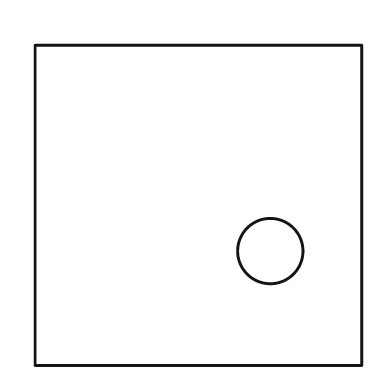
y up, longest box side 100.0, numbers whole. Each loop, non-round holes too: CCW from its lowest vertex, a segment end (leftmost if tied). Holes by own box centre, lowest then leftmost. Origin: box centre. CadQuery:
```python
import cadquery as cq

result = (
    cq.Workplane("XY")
    .moveTo(-50.0, -49.0)
    .lineTo(50.0, -49.0)
    .lineTo(50.0, 49.0)
    .lineTo(-50.0, 49.0)
    .close()
    .moveTo(22.0, -14.0)
    .circle(10.0)
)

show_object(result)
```